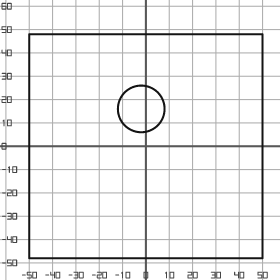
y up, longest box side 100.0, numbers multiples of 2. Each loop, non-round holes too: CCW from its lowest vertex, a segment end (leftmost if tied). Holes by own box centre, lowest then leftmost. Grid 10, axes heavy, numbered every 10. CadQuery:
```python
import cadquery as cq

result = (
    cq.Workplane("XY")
    .moveTo(-50.0, -48.0)
    .lineTo(50.0, -48.0)
    .lineTo(50.0, 48.0)
    .lineTo(-50.0, 48.0)
    .close()
    .moveTo(-2.0, 16.0)
    .circle(10.0)
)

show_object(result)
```